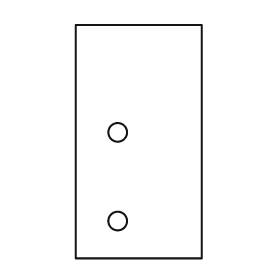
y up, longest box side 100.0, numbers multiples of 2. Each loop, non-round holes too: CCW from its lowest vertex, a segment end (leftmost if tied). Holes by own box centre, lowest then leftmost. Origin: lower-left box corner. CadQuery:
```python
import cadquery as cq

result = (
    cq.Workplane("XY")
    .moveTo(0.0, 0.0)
    .lineTo(54.0, 0.0)
    .lineTo(54.0, 100.0)
    .lineTo(0.0, 100.0)
    .close()
    .moveTo(18.0, 16.0)
    .circle(4.0)
    .moveTo(18.0, 54.0)
    .circle(4.0)
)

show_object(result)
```